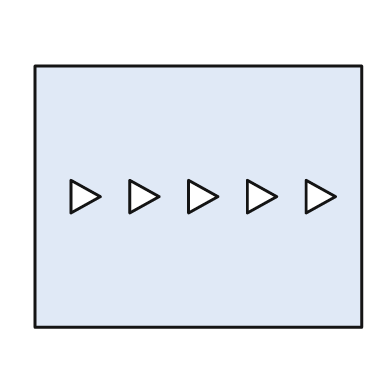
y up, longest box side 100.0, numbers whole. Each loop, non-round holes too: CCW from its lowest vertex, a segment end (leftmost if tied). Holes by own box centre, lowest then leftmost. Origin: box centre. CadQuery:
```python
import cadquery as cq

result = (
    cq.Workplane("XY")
    .moveTo(-50.0, -40.0)
    .lineTo(50.0, -40.0)
    .lineTo(50.0, 40.0)
    .lineTo(-50.0, 40.0)
    .close()
    .moveTo(-39.0, -5.0)
    .lineTo(-30.0, 0.0)
    .lineTo(-39.0, 5.0)
    .close()
    .moveTo(-21.0, -5.0)
    .lineTo(-12.0, 0.0)
    .lineTo(-21.0, 5.0)
    .close()
    .moveTo(-3.0, -5.0)
    .lineTo(6.0, 0.0)
    .lineTo(-3.0, 5.0)
    .close()
    .moveTo(15.0, -5.0)
    .lineTo(24.0, 0.0)
    .lineTo(15.0, 5.0)
    .close()
    .moveTo(33.0, -5.0)
    .lineTo(42.0, 0.0)
    .lineTo(33.0, 5.0)
    .close()
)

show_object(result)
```